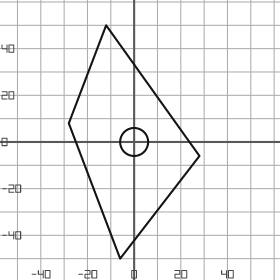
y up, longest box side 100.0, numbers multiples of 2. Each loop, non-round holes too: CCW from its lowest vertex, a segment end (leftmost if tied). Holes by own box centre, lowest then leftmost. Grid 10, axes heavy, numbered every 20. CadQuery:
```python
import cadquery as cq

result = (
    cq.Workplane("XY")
    .moveTo(-6.0, -50.0)
    .lineTo(28.0, -6.0)
    .lineTo(-12.0, 50.0)
    .lineTo(-28.0, 8.0)
    .close()
    .moveTo(0.0, 0.0)
    .circle(6.0)
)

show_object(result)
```